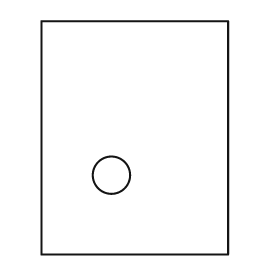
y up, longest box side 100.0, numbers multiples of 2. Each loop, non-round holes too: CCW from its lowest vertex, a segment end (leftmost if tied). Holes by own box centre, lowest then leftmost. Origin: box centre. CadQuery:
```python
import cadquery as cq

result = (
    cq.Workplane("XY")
    .moveTo(-40.0, -50.0)
    .lineTo(40.0, -50.0)
    .lineTo(40.0, 50.0)
    .lineTo(-40.0, 50.0)
    .close()
    .moveTo(-10.0, -16.0)
    .circle(8.0)
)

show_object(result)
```